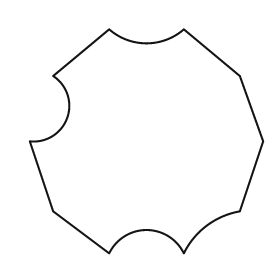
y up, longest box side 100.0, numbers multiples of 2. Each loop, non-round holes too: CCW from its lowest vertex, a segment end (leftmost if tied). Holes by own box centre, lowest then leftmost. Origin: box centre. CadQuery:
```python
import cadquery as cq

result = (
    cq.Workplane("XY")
    .moveTo(-16.0, -48.0)
    .threePointArc((0.0, -38.0), (16.0, -48.0))
    .threePointArc((26.0, -36.0), (40.0, -30.0))
    .lineTo(50.0, 0.0)
    .lineTo(40.0, 28.0)
    .lineTo(16.0, 48.0)
    .threePointArc((0.0, 42.0), (-16.0, 48.0))
    .lineTo(-40.0, 28.0)
    .threePointArc((-34.0, 10.0), (-50.0, 0.0))
    .lineTo(-40.0, -30.0)
    .close()
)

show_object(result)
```